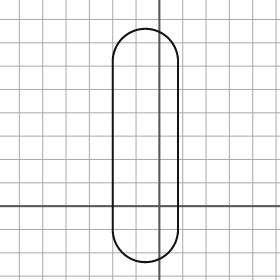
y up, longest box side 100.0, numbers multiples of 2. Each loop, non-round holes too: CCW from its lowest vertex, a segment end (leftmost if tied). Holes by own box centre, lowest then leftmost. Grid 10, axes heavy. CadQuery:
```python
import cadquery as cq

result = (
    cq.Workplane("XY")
    .moveTo(-20.0, -10.0)
    .threePointArc((-6.0, -24.0), (8.0, -10.0))
    .lineTo(8.0, 62.0)
    .threePointArc((-6.0, 76.0), (-20.0, 62.0))
    .close()
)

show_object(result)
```